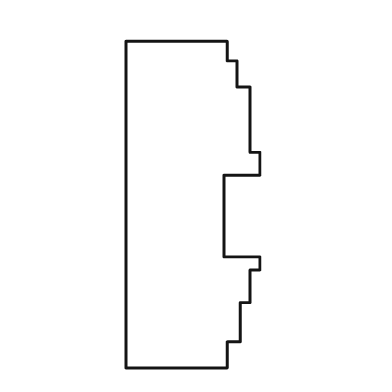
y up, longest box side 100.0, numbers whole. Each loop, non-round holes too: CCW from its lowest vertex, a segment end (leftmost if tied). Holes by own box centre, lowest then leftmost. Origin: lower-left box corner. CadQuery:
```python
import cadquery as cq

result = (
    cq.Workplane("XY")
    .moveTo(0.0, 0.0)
    .lineTo(31.0, 0.0)
    .lineTo(31.0, 8.0)
    .lineTo(35.0, 8.0)
    .lineTo(35.0, 20.0)
    .lineTo(38.0, 20.0)
    .lineTo(38.0, 30.0)
    .lineTo(41.0, 30.0)
    .lineTo(41.0, 34.0)
    .lineTo(30.0, 34.0)
    .lineTo(30.0, 59.0)
    .lineTo(41.0, 59.0)
    .lineTo(41.0, 66.0)
    .lineTo(38.0, 66.0)
    .lineTo(38.0, 86.0)
    .lineTo(34.0, 86.0)
    .lineTo(34.0, 94.0)
    .lineTo(31.0, 94.0)
    .lineTo(31.0, 100.0)
    .lineTo(0.0, 100.0)
    .close()
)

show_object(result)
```